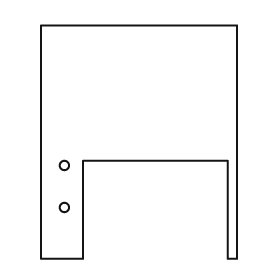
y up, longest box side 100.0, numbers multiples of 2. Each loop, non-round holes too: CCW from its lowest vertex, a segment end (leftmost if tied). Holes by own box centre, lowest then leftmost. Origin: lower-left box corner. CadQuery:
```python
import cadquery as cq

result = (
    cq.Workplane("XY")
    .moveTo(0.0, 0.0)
    .lineTo(18.0, 0.0)
    .lineTo(18.0, 42.0)
    .lineTo(80.0, 42.0)
    .lineTo(80.0, 0.0)
    .lineTo(84.0, 0.0)
    .lineTo(84.0, 100.0)
    .lineTo(0.0, 100.0)
    .close()
    .moveTo(10.0, 22.0)
    .circle(2.0)
    .moveTo(10.0, 40.0)
    .circle(2.0)
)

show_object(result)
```